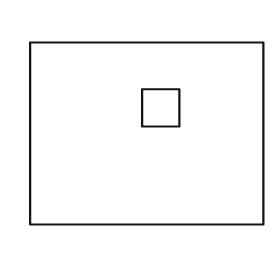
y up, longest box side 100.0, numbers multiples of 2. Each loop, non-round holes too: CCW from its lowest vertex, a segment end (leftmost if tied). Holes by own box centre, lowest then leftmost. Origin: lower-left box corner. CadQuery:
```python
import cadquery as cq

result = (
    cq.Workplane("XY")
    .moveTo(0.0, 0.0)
    .lineTo(100.0, 0.0)
    .lineTo(100.0, 78.0)
    .lineTo(0.0, 78.0)
    .close()
    .moveTo(48.0, 42.0)
    .lineTo(64.0, 42.0)
    .lineTo(64.0, 58.0)
    .lineTo(48.0, 58.0)
    .close()
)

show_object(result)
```